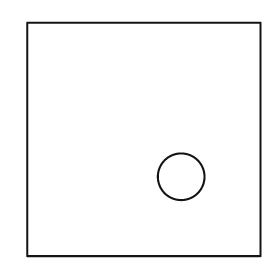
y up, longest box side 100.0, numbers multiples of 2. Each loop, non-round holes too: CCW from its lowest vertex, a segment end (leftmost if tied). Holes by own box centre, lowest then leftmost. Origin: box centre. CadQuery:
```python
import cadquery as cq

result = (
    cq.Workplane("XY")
    .moveTo(-50.0, -50.0)
    .lineTo(50.0, -50.0)
    .lineTo(50.0, 50.0)
    .lineTo(-50.0, 50.0)
    .close()
    .moveTo(16.0, -16.0)
    .circle(10.0)
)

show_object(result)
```